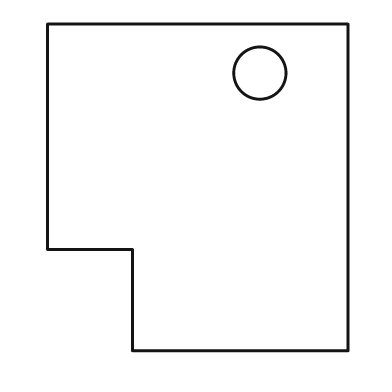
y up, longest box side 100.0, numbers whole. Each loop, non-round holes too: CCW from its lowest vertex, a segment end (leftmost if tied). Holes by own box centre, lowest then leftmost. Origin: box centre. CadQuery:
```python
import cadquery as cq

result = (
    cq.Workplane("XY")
    .moveTo(-20.0, -50.0)
    .lineTo(46.0, -50.0)
    .lineTo(46.0, 50.0)
    .lineTo(-46.0, 50.0)
    .lineTo(-46.0, -19.0)
    .lineTo(-20.0, -19.0)
    .close()
    .moveTo(19.0, 35.0)
    .circle(8.0)
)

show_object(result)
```